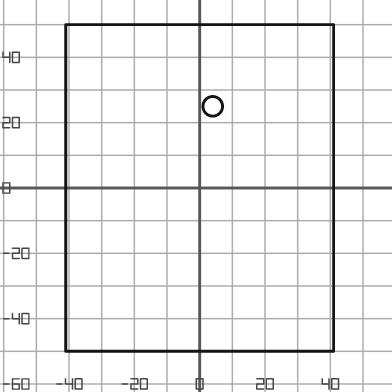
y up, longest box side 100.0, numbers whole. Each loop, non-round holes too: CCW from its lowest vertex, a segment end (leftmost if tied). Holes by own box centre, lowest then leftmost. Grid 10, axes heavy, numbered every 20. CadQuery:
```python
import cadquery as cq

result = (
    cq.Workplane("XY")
    .moveTo(-41.0, -50.0)
    .lineTo(41.0, -50.0)
    .lineTo(41.0, 50.0)
    .lineTo(-41.0, 50.0)
    .close()
    .moveTo(4.0, 25.0)
    .circle(3.0)
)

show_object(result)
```